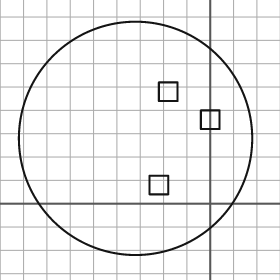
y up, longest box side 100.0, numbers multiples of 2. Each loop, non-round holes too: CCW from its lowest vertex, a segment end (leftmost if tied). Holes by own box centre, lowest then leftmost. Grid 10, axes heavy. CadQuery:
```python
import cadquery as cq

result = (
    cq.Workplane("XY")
    .moveTo(-32.0, 28.0)
    .circle(50.0)
    .moveTo(-26.0, 4.0)
    .lineTo(-18.0, 4.0)
    .lineTo(-18.0, 12.0)
    .lineTo(-26.0, 12.0)
    .close()
    .moveTo(-4.0, 32.0)
    .lineTo(4.0, 32.0)
    .lineTo(4.0, 40.0)
    .lineTo(-4.0, 40.0)
    .close()
    .moveTo(-22.0, 44.0)
    .lineTo(-14.0, 44.0)
    .lineTo(-14.0, 52.0)
    .lineTo(-22.0, 52.0)
    .close()
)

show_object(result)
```